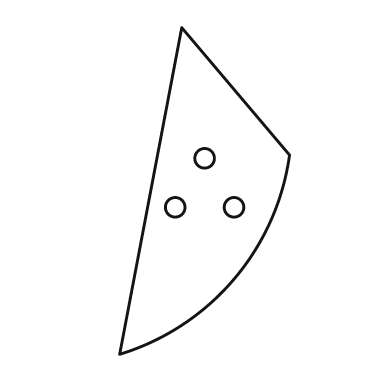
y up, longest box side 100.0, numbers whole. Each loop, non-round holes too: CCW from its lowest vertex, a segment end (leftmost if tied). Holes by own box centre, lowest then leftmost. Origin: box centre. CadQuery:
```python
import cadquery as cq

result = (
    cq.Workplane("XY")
    .moveTo(-26.0, -50.0)
    .threePointArc((9.0, -27.0), (26.0, 11.0))
    .lineTo(-7.0, 50.0)
    .close()
    .moveTo(-9.0, -5.0)
    .circle(3.0)
    .moveTo(9.0, -5.0)
    .circle(3.0)
    .moveTo(0.0, 10.0)
    .circle(3.0)
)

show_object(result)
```